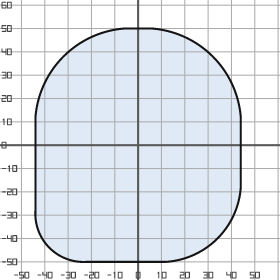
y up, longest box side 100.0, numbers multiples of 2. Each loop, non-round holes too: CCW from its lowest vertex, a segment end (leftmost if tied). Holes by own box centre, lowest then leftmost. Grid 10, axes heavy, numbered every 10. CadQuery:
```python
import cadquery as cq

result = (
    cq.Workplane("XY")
    .moveTo(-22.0, -50.0)
    .lineTo(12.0, -50.0)
    .threePointArc((34.0, -40.0), (44.0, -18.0))
    .lineTo(44.0, 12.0)
    .threePointArc((32.0, 38.0), (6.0, 50.0))
    .lineTo(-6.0, 50.0)
    .threePointArc((-32.0, 38.0), (-44.0, 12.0))
    .lineTo(-44.0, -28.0)
    .threePointArc((-38.0, -44.0), (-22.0, -50.0))
    .close()
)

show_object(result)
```